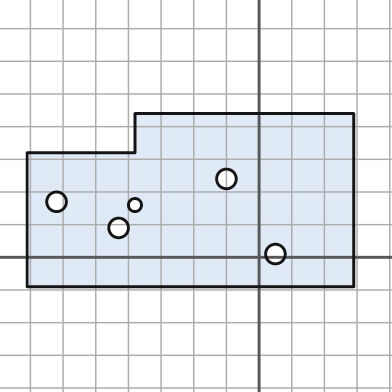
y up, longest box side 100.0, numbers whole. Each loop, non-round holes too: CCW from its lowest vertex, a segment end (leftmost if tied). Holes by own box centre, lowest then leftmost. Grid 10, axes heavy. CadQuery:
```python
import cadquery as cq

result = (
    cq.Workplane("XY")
    .moveTo(-71.0, -9.0)
    .lineTo(29.0, -9.0)
    .lineTo(29.0, 44.0)
    .lineTo(-38.0, 44.0)
    .lineTo(-38.0, 32.0)
    .lineTo(-71.0, 32.0)
    .close()
    .moveTo(5.0, 1.0)
    .circle(3.0)
    .moveTo(-43.0, 9.0)
    .circle(3.0)
    .moveTo(-38.0, 16.0)
    .circle(2.0)
    .moveTo(-62.0, 17.0)
    .circle(3.0)
    .moveTo(-10.0, 24.0)
    .circle(3.0)
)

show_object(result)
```